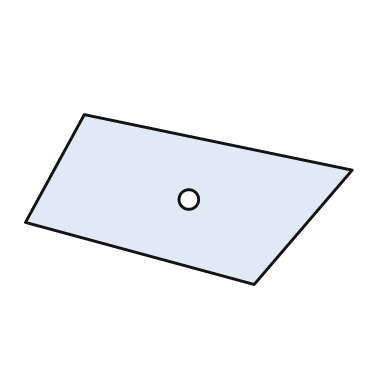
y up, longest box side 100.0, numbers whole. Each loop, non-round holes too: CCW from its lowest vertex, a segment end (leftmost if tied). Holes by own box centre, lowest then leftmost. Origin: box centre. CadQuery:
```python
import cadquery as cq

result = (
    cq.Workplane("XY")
    .moveTo(20.0, -26.0)
    .lineTo(50.0, 9.0)
    .lineTo(-32.0, 26.0)
    .lineTo(-50.0, -7.0)
    .close()
    .moveTo(0.0, 0.0)
    .circle(3.0)
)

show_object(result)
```